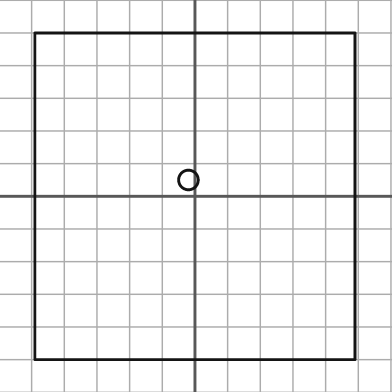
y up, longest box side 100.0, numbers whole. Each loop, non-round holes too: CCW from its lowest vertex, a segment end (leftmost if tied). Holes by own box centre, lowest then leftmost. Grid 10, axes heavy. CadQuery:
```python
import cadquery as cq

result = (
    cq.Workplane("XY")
    .moveTo(-49.0, -50.0)
    .lineTo(49.0, -50.0)
    .lineTo(49.0, 50.0)
    .lineTo(-49.0, 50.0)
    .close()
    .moveTo(-2.0, 5.0)
    .circle(3.0)
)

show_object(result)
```